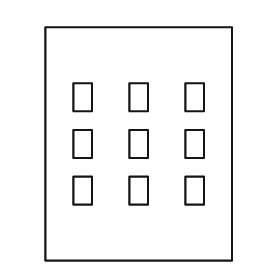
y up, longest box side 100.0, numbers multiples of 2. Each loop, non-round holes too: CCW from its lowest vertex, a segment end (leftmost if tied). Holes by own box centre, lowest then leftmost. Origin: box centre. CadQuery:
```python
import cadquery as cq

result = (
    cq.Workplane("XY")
    .moveTo(-40.0, -50.0)
    .lineTo(40.0, -50.0)
    .lineTo(40.0, 50.0)
    .lineTo(-40.0, 50.0)
    .close()
    .moveTo(-28.0, -26.0)
    .lineTo(-20.0, -26.0)
    .lineTo(-20.0, -14.0)
    .lineTo(-28.0, -14.0)
    .close()
    .moveTo(-4.0, -26.0)
    .lineTo(4.0, -26.0)
    .lineTo(4.0, -14.0)
    .lineTo(-4.0, -14.0)
    .close()
    .moveTo(20.0, -26.0)
    .lineTo(28.0, -26.0)
    .lineTo(28.0, -14.0)
    .lineTo(20.0, -14.0)
    .close()
    .moveTo(-28.0, -6.0)
    .lineTo(-20.0, -6.0)
    .lineTo(-20.0, 6.0)
    .lineTo(-28.0, 6.0)
    .close()
    .moveTo(-4.0, -6.0)
    .lineTo(4.0, -6.0)
    .lineTo(4.0, 6.0)
    .lineTo(-4.0, 6.0)
    .close()
    .moveTo(20.0, -6.0)
    .lineTo(28.0, -6.0)
    .lineTo(28.0, 6.0)
    .lineTo(20.0, 6.0)
    .close()
    .moveTo(-28.0, 14.0)
    .lineTo(-20.0, 14.0)
    .lineTo(-20.0, 26.0)
    .lineTo(-28.0, 26.0)
    .close()
    .moveTo(-4.0, 14.0)
    .lineTo(4.0, 14.0)
    .lineTo(4.0, 26.0)
    .lineTo(-4.0, 26.0)
    .close()
    .moveTo(20.0, 14.0)
    .lineTo(28.0, 14.0)
    .lineTo(28.0, 26.0)
    .lineTo(20.0, 26.0)
    .close()
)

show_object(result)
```